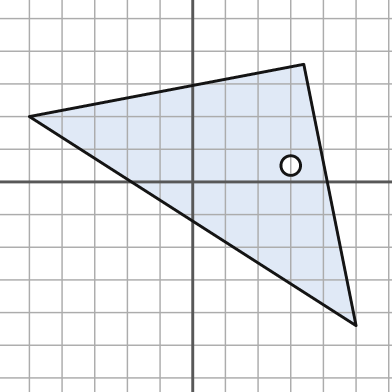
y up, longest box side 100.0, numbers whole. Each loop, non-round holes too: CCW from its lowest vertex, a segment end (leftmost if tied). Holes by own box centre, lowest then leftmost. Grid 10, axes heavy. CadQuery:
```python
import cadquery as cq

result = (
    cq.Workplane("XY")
    .moveTo(50.0, -44.0)
    .lineTo(34.0, 36.0)
    .lineTo(-50.0, 20.0)
    .close()
    .moveTo(30.0, 5.0)
    .circle(3.0)
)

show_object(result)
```